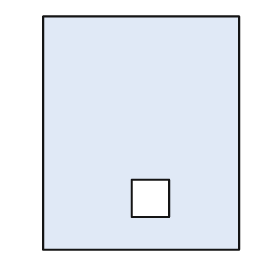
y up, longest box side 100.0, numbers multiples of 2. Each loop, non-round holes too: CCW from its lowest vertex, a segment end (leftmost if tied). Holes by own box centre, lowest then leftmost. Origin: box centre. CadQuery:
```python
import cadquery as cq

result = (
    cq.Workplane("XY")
    .moveTo(-42.0, -50.0)
    .lineTo(42.0, -50.0)
    .lineTo(42.0, 50.0)
    .lineTo(-42.0, 50.0)
    .close()
    .moveTo(-4.0, -36.0)
    .lineTo(12.0, -36.0)
    .lineTo(12.0, -20.0)
    .lineTo(-4.0, -20.0)
    .close()
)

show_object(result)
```